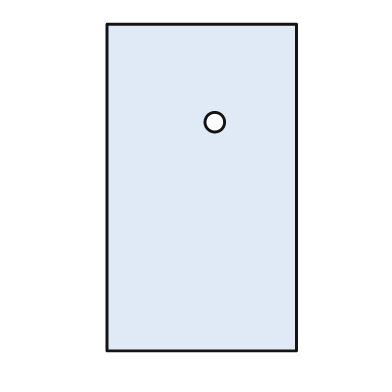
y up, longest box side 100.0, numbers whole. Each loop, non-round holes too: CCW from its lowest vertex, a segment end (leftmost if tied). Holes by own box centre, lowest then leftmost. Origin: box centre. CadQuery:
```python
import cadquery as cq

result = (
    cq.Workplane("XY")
    .moveTo(-29.0, -50.0)
    .lineTo(29.0, -50.0)
    .lineTo(29.0, 50.0)
    .lineTo(-29.0, 50.0)
    .close()
    .moveTo(4.0, 20.0)
    .circle(3.0)
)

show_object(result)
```